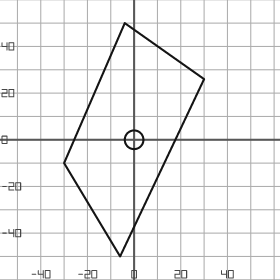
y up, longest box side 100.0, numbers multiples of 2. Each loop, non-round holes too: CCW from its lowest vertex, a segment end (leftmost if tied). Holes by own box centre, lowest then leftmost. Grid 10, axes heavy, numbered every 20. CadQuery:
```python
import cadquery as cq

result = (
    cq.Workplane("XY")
    .moveTo(-6.0, -50.0)
    .lineTo(30.0, 26.0)
    .lineTo(-4.0, 50.0)
    .lineTo(-30.0, -10.0)
    .close()
    .moveTo(0.0, 0.0)
    .circle(4.0)
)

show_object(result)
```